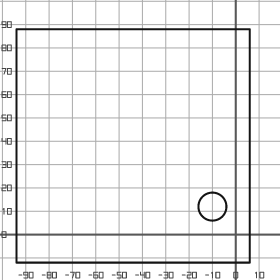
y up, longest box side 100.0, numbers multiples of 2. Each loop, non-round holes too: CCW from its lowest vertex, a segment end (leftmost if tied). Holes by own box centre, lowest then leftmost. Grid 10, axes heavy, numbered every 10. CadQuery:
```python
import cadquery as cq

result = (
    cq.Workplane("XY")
    .moveTo(-94.0, -12.0)
    .lineTo(6.0, -12.0)
    .lineTo(6.0, 88.0)
    .lineTo(-94.0, 88.0)
    .close()
    .moveTo(-10.0, 12.0)
    .circle(6.0)
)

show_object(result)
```